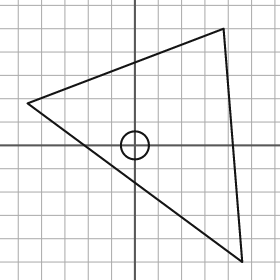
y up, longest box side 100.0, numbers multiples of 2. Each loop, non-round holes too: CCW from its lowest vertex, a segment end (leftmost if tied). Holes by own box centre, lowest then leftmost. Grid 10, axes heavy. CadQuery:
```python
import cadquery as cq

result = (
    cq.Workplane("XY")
    .moveTo(46.0, -50.0)
    .lineTo(38.0, 50.0)
    .lineTo(-46.0, 18.0)
    .close()
    .moveTo(0.0, 0.0)
    .circle(6.0)
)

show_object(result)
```